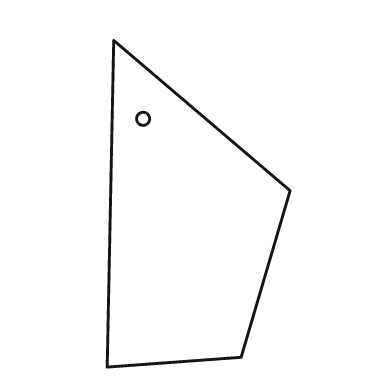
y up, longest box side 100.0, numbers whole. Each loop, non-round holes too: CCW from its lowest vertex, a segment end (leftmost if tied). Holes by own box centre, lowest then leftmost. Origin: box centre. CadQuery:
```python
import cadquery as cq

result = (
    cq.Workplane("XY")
    .moveTo(-28.0, -50.0)
    .lineTo(13.0, -47.0)
    .lineTo(28.0, 4.0)
    .lineTo(-26.0, 50.0)
    .close()
    .moveTo(-17.0, 26.0)
    .circle(2.0)
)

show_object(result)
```